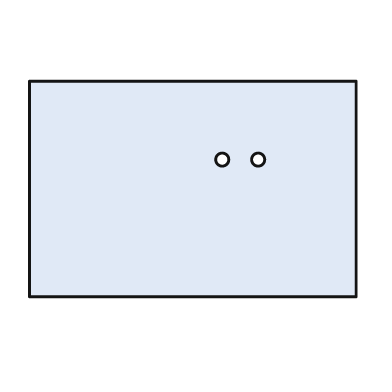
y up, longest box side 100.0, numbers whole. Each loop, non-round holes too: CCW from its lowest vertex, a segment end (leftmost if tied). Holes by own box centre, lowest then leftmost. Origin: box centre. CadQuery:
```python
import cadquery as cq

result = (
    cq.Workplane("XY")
    .moveTo(-50.0, -33.0)
    .lineTo(50.0, -33.0)
    .lineTo(50.0, 33.0)
    .lineTo(-50.0, 33.0)
    .close()
    .moveTo(9.0, 9.0)
    .circle(2.0)
    .moveTo(20.0, 9.0)
    .circle(2.0)
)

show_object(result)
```